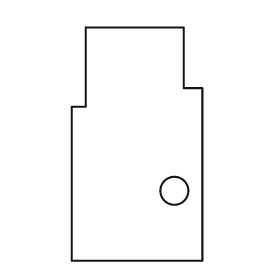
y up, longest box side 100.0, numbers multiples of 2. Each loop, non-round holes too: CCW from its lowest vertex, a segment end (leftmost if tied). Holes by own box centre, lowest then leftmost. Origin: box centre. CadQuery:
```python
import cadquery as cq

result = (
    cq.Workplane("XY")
    .moveTo(-28.0, -50.0)
    .lineTo(28.0, -50.0)
    .lineTo(28.0, 24.0)
    .lineTo(20.0, 24.0)
    .lineTo(20.0, 50.0)
    .lineTo(-22.0, 50.0)
    .lineTo(-22.0, 16.0)
    .lineTo(-28.0, 16.0)
    .close()
    .moveTo(16.0, -20.0)
    .circle(6.0)
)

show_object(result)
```